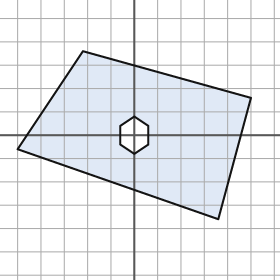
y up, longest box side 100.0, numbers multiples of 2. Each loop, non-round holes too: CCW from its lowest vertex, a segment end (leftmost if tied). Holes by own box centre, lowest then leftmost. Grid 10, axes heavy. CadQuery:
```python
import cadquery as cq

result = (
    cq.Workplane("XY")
    .moveTo(36.0, -36.0)
    .lineTo(50.0, 16.0)
    .lineTo(-22.0, 36.0)
    .lineTo(-50.0, -6.0)
    .close()
    .moveTo(0.0, -8.0)
    .lineTo(6.0, -4.0)
    .lineTo(6.0, 4.0)
    .lineTo(0.0, 8.0)
    .lineTo(-6.0, 4.0)
    .lineTo(-6.0, -4.0)
    .close()
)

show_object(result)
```